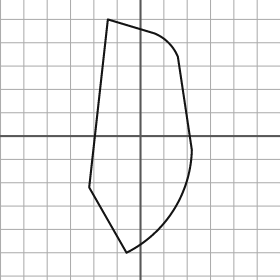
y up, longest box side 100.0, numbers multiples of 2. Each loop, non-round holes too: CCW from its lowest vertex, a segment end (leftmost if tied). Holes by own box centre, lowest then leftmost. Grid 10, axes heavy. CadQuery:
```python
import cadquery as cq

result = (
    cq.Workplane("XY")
    .moveTo(-6.0, -50.0)
    .threePointArc((14.0, -32.0), (22.0, -6.0))
    .lineTo(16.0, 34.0)
    .threePointArc((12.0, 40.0), (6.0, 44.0))
    .lineTo(-14.0, 50.0)
    .lineTo(-22.0, -22.0)
    .close()
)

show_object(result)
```